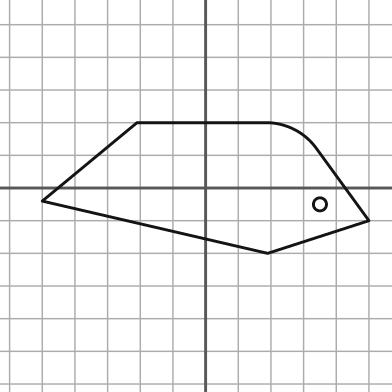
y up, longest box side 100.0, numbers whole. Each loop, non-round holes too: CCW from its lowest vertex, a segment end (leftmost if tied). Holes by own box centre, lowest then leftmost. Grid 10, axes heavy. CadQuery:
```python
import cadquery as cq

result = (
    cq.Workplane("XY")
    .moveTo(19.0, -20.0)
    .lineTo(50.0, -10.0)
    .lineTo(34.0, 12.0)
    .threePointArc((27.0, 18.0), (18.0, 20.0))
    .lineTo(-21.0, 20.0)
    .lineTo(-50.0, -4.0)
    .close()
    .moveTo(35.0, -5.0)
    .circle(2.0)
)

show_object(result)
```